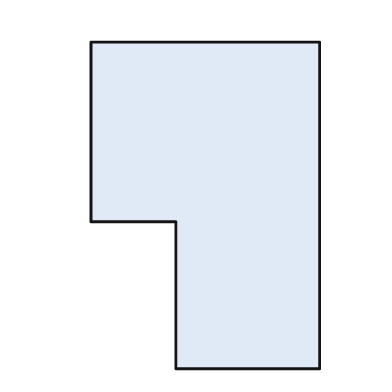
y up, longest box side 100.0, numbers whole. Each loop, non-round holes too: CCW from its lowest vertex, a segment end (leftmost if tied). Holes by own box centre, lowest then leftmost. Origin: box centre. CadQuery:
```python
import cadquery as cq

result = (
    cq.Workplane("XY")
    .moveTo(-9.0, -50.0)
    .lineTo(35.0, -50.0)
    .lineTo(35.0, 50.0)
    .lineTo(-35.0, 50.0)
    .lineTo(-35.0, -5.0)
    .lineTo(-9.0, -5.0)
    .close()
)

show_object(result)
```